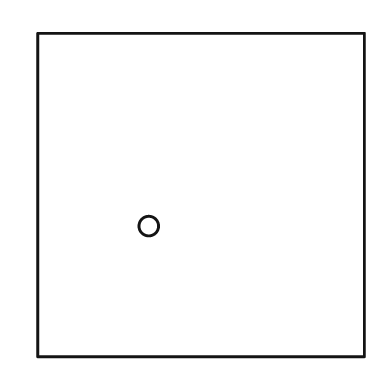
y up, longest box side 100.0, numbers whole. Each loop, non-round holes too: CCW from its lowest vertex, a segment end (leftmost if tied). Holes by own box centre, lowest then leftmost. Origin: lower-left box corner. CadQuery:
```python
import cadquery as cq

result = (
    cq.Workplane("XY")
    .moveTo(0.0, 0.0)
    .lineTo(100.0, 0.0)
    .lineTo(100.0, 99.0)
    .lineTo(0.0, 99.0)
    .close()
    .moveTo(34.0, 40.0)
    .circle(3.0)
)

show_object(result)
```